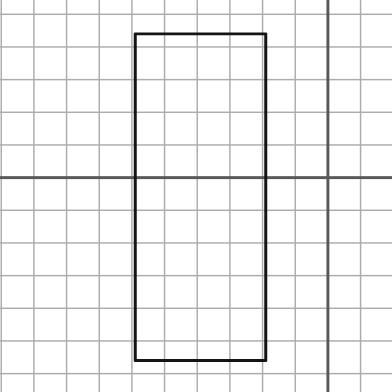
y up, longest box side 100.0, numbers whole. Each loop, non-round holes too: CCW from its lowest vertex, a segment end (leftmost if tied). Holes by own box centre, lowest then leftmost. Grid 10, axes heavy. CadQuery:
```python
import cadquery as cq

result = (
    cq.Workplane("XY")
    .moveTo(-59.0, -56.0)
    .lineTo(-19.0, -56.0)
    .lineTo(-19.0, 44.0)
    .lineTo(-59.0, 44.0)
    .close()
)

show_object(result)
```